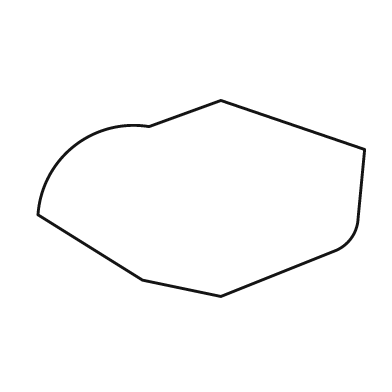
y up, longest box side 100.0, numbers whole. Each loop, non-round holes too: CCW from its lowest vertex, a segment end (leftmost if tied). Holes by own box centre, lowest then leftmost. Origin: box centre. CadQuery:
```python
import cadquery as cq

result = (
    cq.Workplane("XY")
    .moveTo(6.0, -30.0)
    .lineTo(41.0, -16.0)
    .threePointArc((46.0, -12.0), (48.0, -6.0))
    .lineTo(50.0, 15.0)
    .lineTo(6.0, 30.0)
    .lineTo(-16.0, 22.0)
    .threePointArc((-39.0, 16.0), (-50.0, -5.0))
    .lineTo(-18.0, -25.0)
    .close()
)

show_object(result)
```